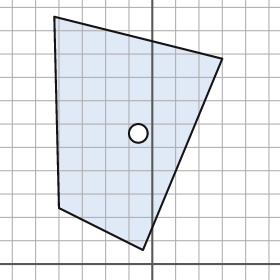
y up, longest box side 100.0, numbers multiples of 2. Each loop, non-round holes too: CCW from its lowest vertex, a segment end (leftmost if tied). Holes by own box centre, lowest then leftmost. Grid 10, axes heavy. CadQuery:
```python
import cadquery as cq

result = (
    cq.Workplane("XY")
    .moveTo(-4.0, 6.0)
    .lineTo(30.0, 88.0)
    .lineTo(-42.0, 106.0)
    .lineTo(-40.0, 24.0)
    .close()
    .moveTo(-6.0, 56.0)
    .circle(4.0)
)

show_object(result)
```